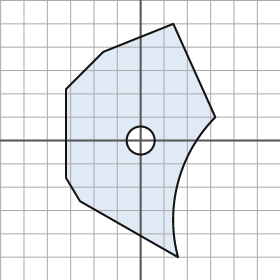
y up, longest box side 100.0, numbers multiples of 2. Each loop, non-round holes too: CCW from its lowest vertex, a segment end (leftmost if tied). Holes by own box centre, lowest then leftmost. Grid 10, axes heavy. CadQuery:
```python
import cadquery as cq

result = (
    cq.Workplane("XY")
    .moveTo(16.0, -50.0)
    .threePointArc((16.0, -18.0), (32.0, 10.0))
    .lineTo(14.0, 50.0)
    .lineTo(-16.0, 38.0)
    .lineTo(-32.0, 22.0)
    .lineTo(-32.0, -16.0)
    .lineTo(-26.0, -26.0)
    .close()
    .moveTo(0.0, 0.0)
    .circle(6.0)
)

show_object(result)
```